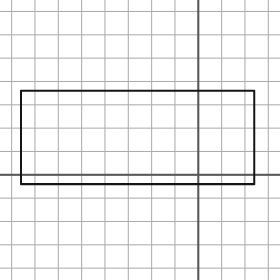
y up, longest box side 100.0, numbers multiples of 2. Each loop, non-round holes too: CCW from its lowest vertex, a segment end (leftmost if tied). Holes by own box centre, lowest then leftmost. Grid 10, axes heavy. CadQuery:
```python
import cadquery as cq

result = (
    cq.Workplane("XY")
    .moveTo(-76.0, -4.0)
    .lineTo(24.0, -4.0)
    .lineTo(24.0, 36.0)
    .lineTo(-76.0, 36.0)
    .close()
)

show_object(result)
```